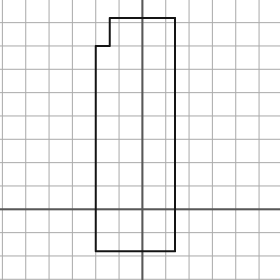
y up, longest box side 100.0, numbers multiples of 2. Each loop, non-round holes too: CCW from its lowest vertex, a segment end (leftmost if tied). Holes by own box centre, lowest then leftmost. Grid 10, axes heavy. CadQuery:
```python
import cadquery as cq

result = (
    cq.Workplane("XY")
    .moveTo(-20.0, -18.0)
    .lineTo(14.0, -18.0)
    .lineTo(14.0, 82.0)
    .lineTo(-14.0, 82.0)
    .lineTo(-14.0, 70.0)
    .lineTo(-20.0, 70.0)
    .close()
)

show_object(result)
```